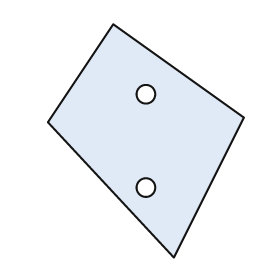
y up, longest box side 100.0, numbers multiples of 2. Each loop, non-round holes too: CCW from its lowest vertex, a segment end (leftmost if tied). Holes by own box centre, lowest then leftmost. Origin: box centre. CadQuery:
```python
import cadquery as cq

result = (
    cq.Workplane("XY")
    .moveTo(12.0, -50.0)
    .lineTo(42.0, 10.0)
    .lineTo(-14.0, 50.0)
    .lineTo(-42.0, 8.0)
    .close()
    .moveTo(0.0, -20.0)
    .circle(4.0)
    .moveTo(0.0, 20.0)
    .circle(4.0)
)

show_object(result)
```